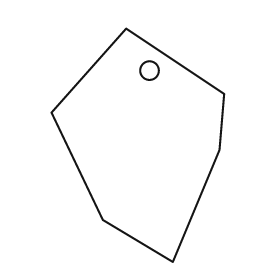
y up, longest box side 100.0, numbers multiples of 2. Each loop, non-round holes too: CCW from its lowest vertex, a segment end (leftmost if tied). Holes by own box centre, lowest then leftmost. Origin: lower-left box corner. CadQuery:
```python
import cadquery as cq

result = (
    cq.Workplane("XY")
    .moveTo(52.0, 0.0)
    .lineTo(72.0, 48.0)
    .lineTo(74.0, 72.0)
    .lineTo(32.0, 100.0)
    .lineTo(0.0, 64.0)
    .lineTo(22.0, 18.0)
    .close()
    .moveTo(42.0, 82.0)
    .circle(4.0)
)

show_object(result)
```